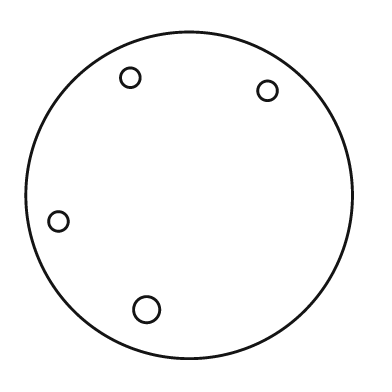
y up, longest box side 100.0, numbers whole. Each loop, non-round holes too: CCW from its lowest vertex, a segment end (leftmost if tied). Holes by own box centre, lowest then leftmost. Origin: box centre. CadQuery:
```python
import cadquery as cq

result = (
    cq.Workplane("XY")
    .moveTo(0.0, 0.0)
    .circle(50.0)
    .moveTo(-13.0, -35.0)
    .circle(4.0)
    .moveTo(-40.0, -8.0)
    .circle(3.0)
    .moveTo(24.0, 32.0)
    .circle(3.0)
    .moveTo(-18.0, 36.0)
    .circle(3.0)
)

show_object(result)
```